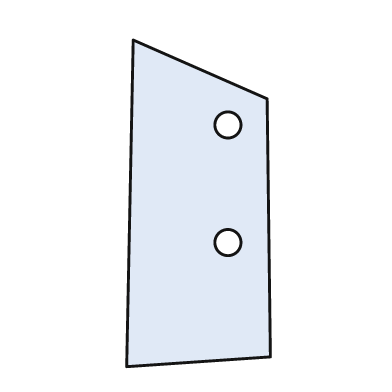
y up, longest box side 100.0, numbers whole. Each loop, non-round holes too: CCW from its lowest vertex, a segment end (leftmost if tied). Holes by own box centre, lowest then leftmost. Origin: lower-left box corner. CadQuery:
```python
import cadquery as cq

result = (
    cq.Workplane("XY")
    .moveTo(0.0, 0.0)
    .lineTo(44.0, 3.0)
    .lineTo(43.0, 82.0)
    .lineTo(2.0, 100.0)
    .close()
    .moveTo(31.0, 38.0)
    .circle(4.0)
    .moveTo(31.0, 74.0)
    .circle(4.0)
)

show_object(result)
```